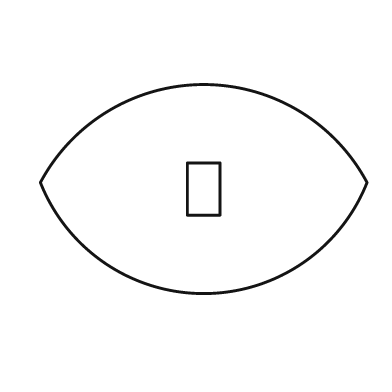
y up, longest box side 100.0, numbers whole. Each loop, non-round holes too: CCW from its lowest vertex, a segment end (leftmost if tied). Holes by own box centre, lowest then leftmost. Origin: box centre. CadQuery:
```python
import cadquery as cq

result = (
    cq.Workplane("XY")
    .moveTo(-50.0, 2.0)
    .threePointArc((0.0, -32.0), (50.0, 2.0))
    .threePointArc((0.0, 32.0), (-50.0, 2.0))
    .close()
    .moveTo(-5.0, -8.0)
    .lineTo(5.0, -8.0)
    .lineTo(5.0, 8.0)
    .lineTo(-5.0, 8.0)
    .close()
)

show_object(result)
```